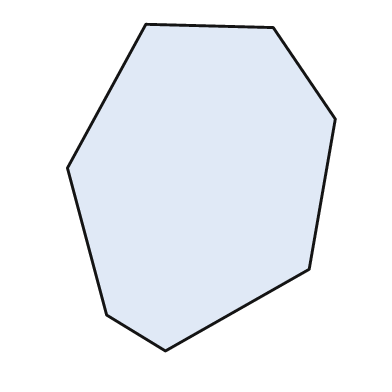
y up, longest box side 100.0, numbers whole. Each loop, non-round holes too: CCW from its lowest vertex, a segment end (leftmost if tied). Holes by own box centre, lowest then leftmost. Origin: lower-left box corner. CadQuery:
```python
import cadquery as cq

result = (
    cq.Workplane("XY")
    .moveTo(30.0, 0.0)
    .lineTo(74.0, 25.0)
    .lineTo(82.0, 71.0)
    .lineTo(63.0, 99.0)
    .lineTo(24.0, 100.0)
    .lineTo(0.0, 56.0)
    .lineTo(12.0, 11.0)
    .close()
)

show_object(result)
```